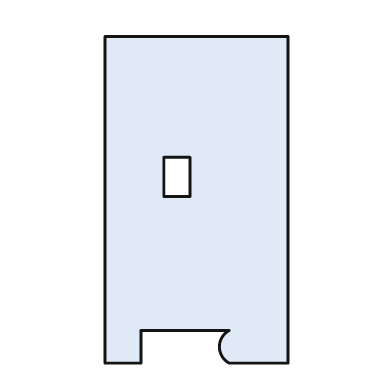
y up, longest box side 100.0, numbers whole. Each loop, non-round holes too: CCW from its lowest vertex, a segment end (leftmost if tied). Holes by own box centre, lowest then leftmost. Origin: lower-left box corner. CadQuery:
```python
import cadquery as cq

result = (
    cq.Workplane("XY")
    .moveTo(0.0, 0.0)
    .lineTo(11.0, 0.0)
    .lineTo(11.0, 10.0)
    .lineTo(38.0, 10.0)
    .threePointArc((35.0, 5.0), (38.0, 0.0))
    .lineTo(56.0, 0.0)
    .lineTo(56.0, 100.0)
    .lineTo(0.0, 100.0)
    .close()
    .moveTo(18.0, 51.0)
    .lineTo(26.0, 51.0)
    .lineTo(26.0, 63.0)
    .lineTo(18.0, 63.0)
    .close()
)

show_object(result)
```